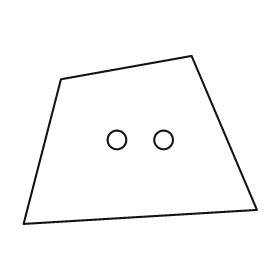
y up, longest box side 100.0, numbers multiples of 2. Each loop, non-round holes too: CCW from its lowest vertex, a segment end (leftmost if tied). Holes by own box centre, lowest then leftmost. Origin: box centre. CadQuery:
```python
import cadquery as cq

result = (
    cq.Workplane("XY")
    .moveTo(-50.0, -36.0)
    .lineTo(50.0, -30.0)
    .lineTo(22.0, 36.0)
    .lineTo(-34.0, 26.0)
    .close()
    .moveTo(-10.0, 0.0)
    .circle(4.0)
    .moveTo(10.0, 0.0)
    .circle(4.0)
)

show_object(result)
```